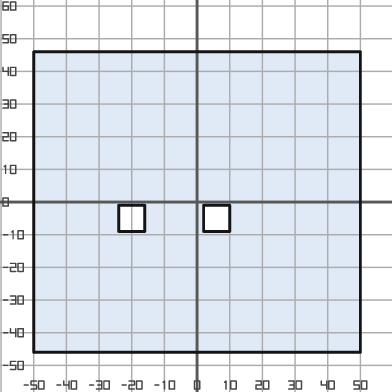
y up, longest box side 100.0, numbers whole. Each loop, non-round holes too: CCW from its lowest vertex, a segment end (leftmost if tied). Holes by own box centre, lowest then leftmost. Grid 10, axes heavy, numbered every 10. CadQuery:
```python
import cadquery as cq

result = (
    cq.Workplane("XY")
    .moveTo(-50.0, -46.0)
    .lineTo(50.0, -46.0)
    .lineTo(50.0, 46.0)
    .lineTo(-50.0, 46.0)
    .close()
    .moveTo(-24.0, -9.0)
    .lineTo(-16.0, -9.0)
    .lineTo(-16.0, -1.0)
    .lineTo(-24.0, -1.0)
    .close()
    .moveTo(2.0, -9.0)
    .lineTo(10.0, -9.0)
    .lineTo(10.0, -1.0)
    .lineTo(2.0, -1.0)
    .close()
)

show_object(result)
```